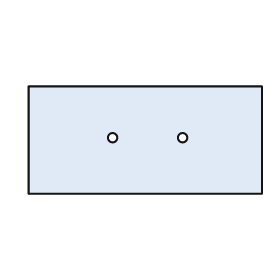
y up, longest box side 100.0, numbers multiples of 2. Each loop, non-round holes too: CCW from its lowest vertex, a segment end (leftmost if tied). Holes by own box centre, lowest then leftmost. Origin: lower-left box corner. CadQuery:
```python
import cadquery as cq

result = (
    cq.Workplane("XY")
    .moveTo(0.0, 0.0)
    .lineTo(100.0, 0.0)
    .lineTo(100.0, 46.0)
    .lineTo(0.0, 46.0)
    .close()
    .moveTo(36.0, 24.0)
    .circle(2.0)
    .moveTo(66.0, 24.0)
    .circle(2.0)
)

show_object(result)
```